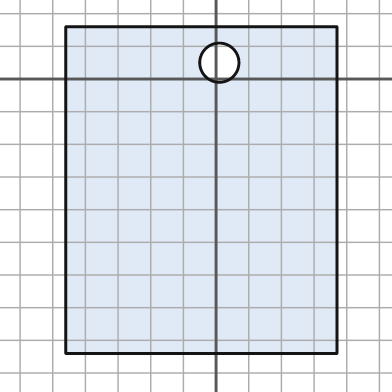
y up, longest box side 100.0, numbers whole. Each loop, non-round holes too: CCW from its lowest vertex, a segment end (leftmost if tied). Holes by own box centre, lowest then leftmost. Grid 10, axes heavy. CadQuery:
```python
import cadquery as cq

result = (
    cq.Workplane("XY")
    .moveTo(-46.0, -84.0)
    .lineTo(37.0, -84.0)
    .lineTo(37.0, 16.0)
    .lineTo(-46.0, 16.0)
    .close()
    .moveTo(1.0, 5.0)
    .circle(6.0)
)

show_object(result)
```